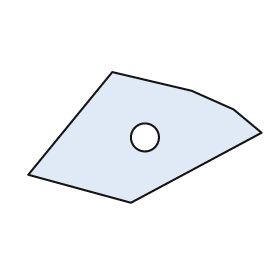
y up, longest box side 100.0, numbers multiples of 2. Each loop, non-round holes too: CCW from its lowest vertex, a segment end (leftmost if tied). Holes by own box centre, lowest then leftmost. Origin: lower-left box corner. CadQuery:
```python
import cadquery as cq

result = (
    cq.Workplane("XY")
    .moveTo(44.0, 0.0)
    .lineTo(100.0, 30.0)
    .lineTo(88.0, 40.0)
    .lineTo(70.0, 48.0)
    .lineTo(36.0, 56.0)
    .lineTo(0.0, 12.0)
    .close()
    .moveTo(50.0, 28.0)
    .circle(6.0)
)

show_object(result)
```